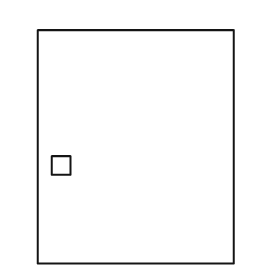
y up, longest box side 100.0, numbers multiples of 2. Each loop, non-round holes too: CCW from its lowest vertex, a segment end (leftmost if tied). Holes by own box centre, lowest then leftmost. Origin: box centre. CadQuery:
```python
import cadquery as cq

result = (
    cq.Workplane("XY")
    .moveTo(-42.0, -50.0)
    .lineTo(42.0, -50.0)
    .lineTo(42.0, 50.0)
    .lineTo(-42.0, 50.0)
    .close()
    .moveTo(-36.0, -12.0)
    .lineTo(-28.0, -12.0)
    .lineTo(-28.0, -4.0)
    .lineTo(-36.0, -4.0)
    .close()
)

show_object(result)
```